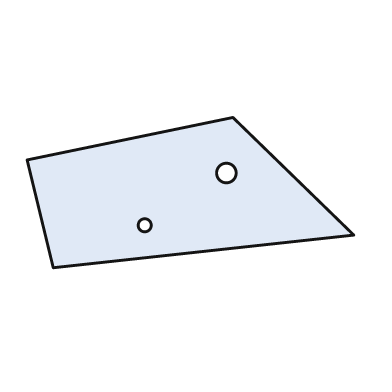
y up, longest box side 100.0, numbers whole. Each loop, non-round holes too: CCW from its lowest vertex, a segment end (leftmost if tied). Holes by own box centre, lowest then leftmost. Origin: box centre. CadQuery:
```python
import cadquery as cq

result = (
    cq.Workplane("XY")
    .moveTo(-42.0, -23.0)
    .lineTo(50.0, -13.0)
    .lineTo(13.0, 23.0)
    .lineTo(-50.0, 10.0)
    .close()
    .moveTo(-14.0, -10.0)
    .circle(2.0)
    .moveTo(11.0, 6.0)
    .circle(3.0)
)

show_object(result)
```